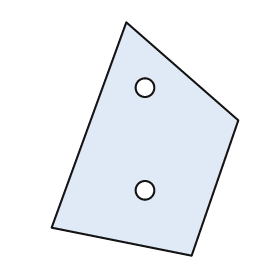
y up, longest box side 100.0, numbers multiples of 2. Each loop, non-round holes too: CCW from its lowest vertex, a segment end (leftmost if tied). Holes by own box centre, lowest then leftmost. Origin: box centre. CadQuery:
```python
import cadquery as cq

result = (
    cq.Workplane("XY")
    .moveTo(20.0, -50.0)
    .lineTo(40.0, 8.0)
    .lineTo(-8.0, 50.0)
    .lineTo(-40.0, -38.0)
    .close()
    .moveTo(0.0, -22.0)
    .circle(4.0)
    .moveTo(0.0, 22.0)
    .circle(4.0)
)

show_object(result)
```